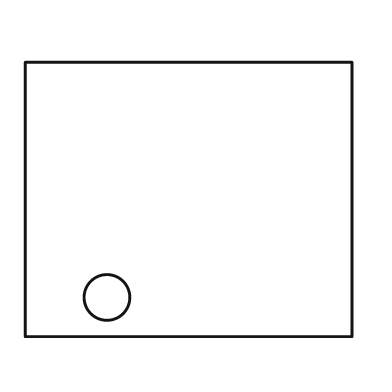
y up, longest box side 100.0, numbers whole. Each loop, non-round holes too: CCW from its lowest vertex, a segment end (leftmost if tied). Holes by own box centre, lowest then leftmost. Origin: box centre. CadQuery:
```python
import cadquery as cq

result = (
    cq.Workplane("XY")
    .moveTo(-50.0, -42.0)
    .lineTo(50.0, -42.0)
    .lineTo(50.0, 42.0)
    .lineTo(-50.0, 42.0)
    .close()
    .moveTo(-25.0, -30.0)
    .circle(7.0)
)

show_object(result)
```